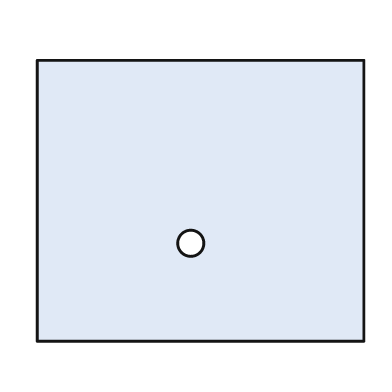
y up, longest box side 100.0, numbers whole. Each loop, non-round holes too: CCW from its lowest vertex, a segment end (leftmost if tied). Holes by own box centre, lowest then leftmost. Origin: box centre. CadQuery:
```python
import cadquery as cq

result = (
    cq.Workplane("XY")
    .moveTo(-50.0, -43.0)
    .lineTo(50.0, -43.0)
    .lineTo(50.0, 43.0)
    .lineTo(-50.0, 43.0)
    .close()
    .moveTo(-3.0, -13.0)
    .circle(4.0)
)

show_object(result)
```